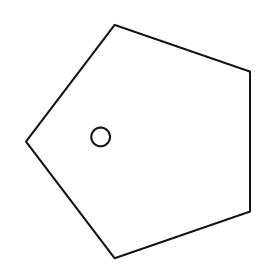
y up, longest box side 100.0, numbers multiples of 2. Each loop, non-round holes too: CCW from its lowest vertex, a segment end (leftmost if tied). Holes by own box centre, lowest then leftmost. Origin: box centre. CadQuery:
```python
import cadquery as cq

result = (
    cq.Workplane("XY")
    .moveTo(-10.0, -50.0)
    .lineTo(48.0, -30.0)
    .lineTo(48.0, 30.0)
    .lineTo(-10.0, 50.0)
    .lineTo(-48.0, 0.0)
    .close()
    .moveTo(-16.0, 2.0)
    .circle(4.0)
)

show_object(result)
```